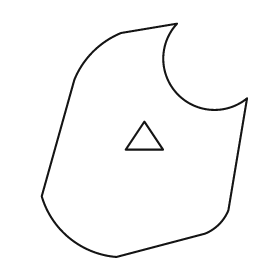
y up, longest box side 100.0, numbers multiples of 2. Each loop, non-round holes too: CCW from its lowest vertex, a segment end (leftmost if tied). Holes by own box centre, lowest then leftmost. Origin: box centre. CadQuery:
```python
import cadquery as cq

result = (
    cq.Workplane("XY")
    .moveTo(-12.0, -50.0)
    .lineTo(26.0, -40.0)
    .threePointArc((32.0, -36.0), (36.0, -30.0))
    .lineTo(44.0, 18.0)
    .threePointArc((14.0, 20.0), (14.0, 50.0))
    .lineTo(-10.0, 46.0)
    .threePointArc((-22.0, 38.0), (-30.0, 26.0))
    .lineTo(-44.0, -24.0)
    .threePointArc((-32.0, -42.0), (-12.0, -50.0))
    .close()
    .moveTo(-8.0, -4.0)
    .lineTo(8.0, -4.0)
    .lineTo(0.0, 8.0)
    .close()
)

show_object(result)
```